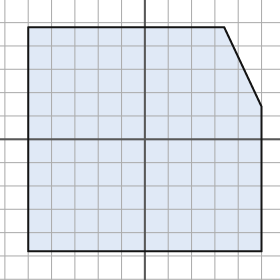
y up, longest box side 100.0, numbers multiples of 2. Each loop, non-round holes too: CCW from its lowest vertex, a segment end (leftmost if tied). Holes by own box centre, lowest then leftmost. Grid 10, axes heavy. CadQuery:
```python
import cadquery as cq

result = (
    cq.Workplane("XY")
    .moveTo(-50.0, -48.0)
    .lineTo(50.0, -48.0)
    .lineTo(50.0, 14.0)
    .lineTo(34.0, 48.0)
    .lineTo(-50.0, 48.0)
    .close()
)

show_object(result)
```